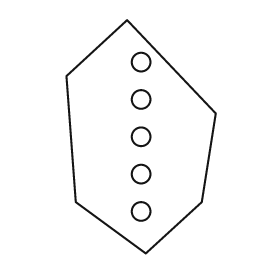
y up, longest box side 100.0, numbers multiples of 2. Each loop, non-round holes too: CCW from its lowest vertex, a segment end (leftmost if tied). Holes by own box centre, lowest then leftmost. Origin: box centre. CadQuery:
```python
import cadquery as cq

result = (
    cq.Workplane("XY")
    .moveTo(2.0, -50.0)
    .lineTo(26.0, -28.0)
    .lineTo(32.0, 10.0)
    .lineTo(-6.0, 50.0)
    .lineTo(-32.0, 26.0)
    .lineTo(-28.0, -28.0)
    .close()
    .moveTo(0.0, -32.0)
    .circle(4.0)
    .moveTo(0.0, -16.0)
    .circle(4.0)
    .moveTo(0.0, 0.0)
    .circle(4.0)
    .moveTo(0.0, 16.0)
    .circle(4.0)
    .moveTo(0.0, 32.0)
    .circle(4.0)
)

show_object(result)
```